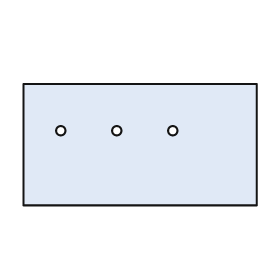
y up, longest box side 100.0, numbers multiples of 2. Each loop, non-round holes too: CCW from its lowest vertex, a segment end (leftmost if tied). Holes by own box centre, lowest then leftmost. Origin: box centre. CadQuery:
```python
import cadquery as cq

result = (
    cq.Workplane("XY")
    .moveTo(-50.0, -26.0)
    .lineTo(50.0, -26.0)
    .lineTo(50.0, 26.0)
    .lineTo(-50.0, 26.0)
    .close()
    .moveTo(-34.0, 6.0)
    .circle(2.0)
    .moveTo(-10.0, 6.0)
    .circle(2.0)
    .moveTo(14.0, 6.0)
    .circle(2.0)
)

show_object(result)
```